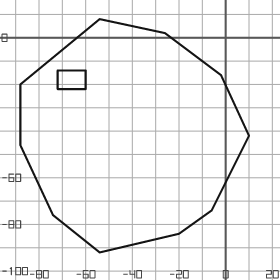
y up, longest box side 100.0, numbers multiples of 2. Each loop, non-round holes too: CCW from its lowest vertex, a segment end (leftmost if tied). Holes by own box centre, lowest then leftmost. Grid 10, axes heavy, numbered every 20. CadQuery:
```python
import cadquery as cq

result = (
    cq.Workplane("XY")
    .moveTo(-54.0, -92.0)
    .lineTo(-20.0, -84.0)
    .lineTo(-6.0, -74.0)
    .lineTo(10.0, -42.0)
    .lineTo(-2.0, -16.0)
    .lineTo(-26.0, 2.0)
    .lineTo(-54.0, 8.0)
    .lineTo(-88.0, -20.0)
    .lineTo(-88.0, -46.0)
    .lineTo(-74.0, -76.0)
    .close()
    .moveTo(-72.0, -22.0)
    .lineTo(-60.0, -22.0)
    .lineTo(-60.0, -14.0)
    .lineTo(-72.0, -14.0)
    .close()
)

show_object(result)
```